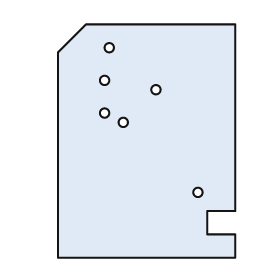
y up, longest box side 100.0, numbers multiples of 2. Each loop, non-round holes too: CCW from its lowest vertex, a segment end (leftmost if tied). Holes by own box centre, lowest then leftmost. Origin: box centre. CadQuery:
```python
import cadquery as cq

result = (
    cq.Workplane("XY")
    .moveTo(-38.0, -50.0)
    .lineTo(38.0, -50.0)
    .lineTo(38.0, -40.0)
    .lineTo(26.0, -40.0)
    .lineTo(26.0, -30.0)
    .lineTo(38.0, -30.0)
    .lineTo(38.0, 50.0)
    .lineTo(-26.0, 50.0)
    .lineTo(-38.0, 38.0)
    .close()
    .moveTo(22.0, -22.0)
    .circle(2.0)
    .moveTo(-10.0, 8.0)
    .circle(2.0)
    .moveTo(-18.0, 12.0)
    .circle(2.0)
    .moveTo(4.0, 22.0)
    .circle(2.0)
    .moveTo(-18.0, 26.0)
    .circle(2.0)
    .moveTo(-16.0, 40.0)
    .circle(2.0)
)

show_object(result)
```